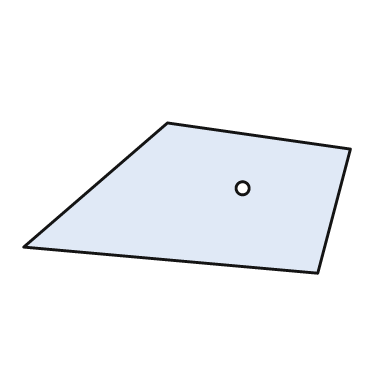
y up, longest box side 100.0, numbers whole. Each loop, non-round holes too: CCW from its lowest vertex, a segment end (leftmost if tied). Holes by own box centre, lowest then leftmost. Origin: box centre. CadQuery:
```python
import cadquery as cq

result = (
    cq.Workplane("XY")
    .moveTo(40.0, -23.0)
    .lineTo(50.0, 15.0)
    .lineTo(-6.0, 23.0)
    .lineTo(-50.0, -15.0)
    .close()
    .moveTo(17.0, 3.0)
    .circle(2.0)
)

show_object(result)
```